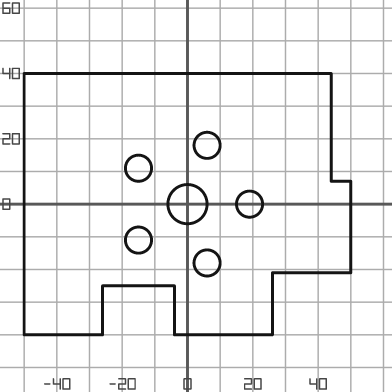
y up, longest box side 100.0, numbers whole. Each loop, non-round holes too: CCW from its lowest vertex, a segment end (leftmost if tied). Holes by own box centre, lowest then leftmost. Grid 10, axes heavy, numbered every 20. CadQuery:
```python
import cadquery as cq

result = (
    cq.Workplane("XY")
    .moveTo(-50.0, -40.0)
    .lineTo(-26.0, -40.0)
    .lineTo(-26.0, -25.0)
    .lineTo(-4.0, -25.0)
    .lineTo(-4.0, -40.0)
    .lineTo(26.0, -40.0)
    .lineTo(26.0, -21.0)
    .lineTo(50.0, -21.0)
    .lineTo(50.0, 7.0)
    .lineTo(44.0, 7.0)
    .lineTo(44.0, 40.0)
    .lineTo(-50.0, 40.0)
    .close()
    .moveTo(6.0, -18.0)
    .circle(4.0)
    .moveTo(-15.0, -11.0)
    .circle(4.0)
    .moveTo(0.0, 0.0)
    .circle(6.0)
    .moveTo(19.0, 0.0)
    .circle(4.0)
    .moveTo(-15.0, 11.0)
    .circle(4.0)
    .moveTo(6.0, 18.0)
    .circle(4.0)
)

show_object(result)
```